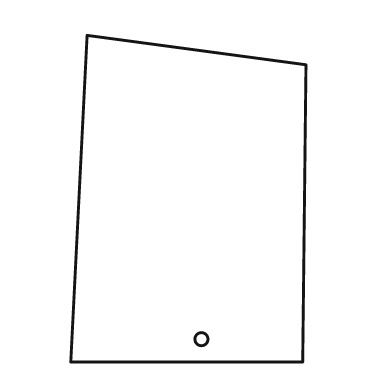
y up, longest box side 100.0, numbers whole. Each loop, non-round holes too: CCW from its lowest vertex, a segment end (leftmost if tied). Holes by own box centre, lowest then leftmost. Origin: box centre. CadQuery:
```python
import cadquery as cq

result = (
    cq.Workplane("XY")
    .moveTo(-36.0, -50.0)
    .lineTo(35.0, -50.0)
    .lineTo(36.0, 41.0)
    .lineTo(-31.0, 50.0)
    .close()
    .moveTo(4.0, -43.0)
    .circle(2.0)
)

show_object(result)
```